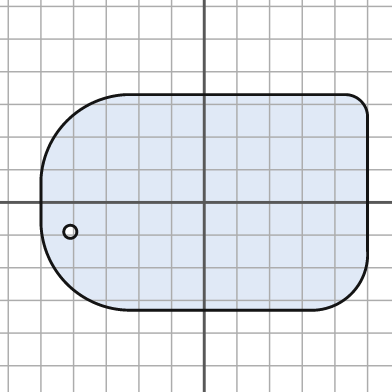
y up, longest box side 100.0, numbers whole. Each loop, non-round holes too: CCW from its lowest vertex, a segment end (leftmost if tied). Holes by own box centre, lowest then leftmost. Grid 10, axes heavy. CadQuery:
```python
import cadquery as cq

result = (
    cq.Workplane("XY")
    .moveTo(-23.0, -33.0)
    .lineTo(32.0, -33.0)
    .threePointArc((45.0, -28.0), (50.0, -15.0))
    .lineTo(50.0, 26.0)
    .threePointArc((48.0, 31.0), (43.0, 33.0))
    .lineTo(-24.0, 33.0)
    .threePointArc((-42.0, 25.0), (-50.0, 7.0))
    .lineTo(-50.0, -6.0)
    .threePointArc((-42.0, -25.0), (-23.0, -33.0))
    .close()
    .moveTo(-41.0, -9.0)
    .circle(2.0)
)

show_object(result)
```